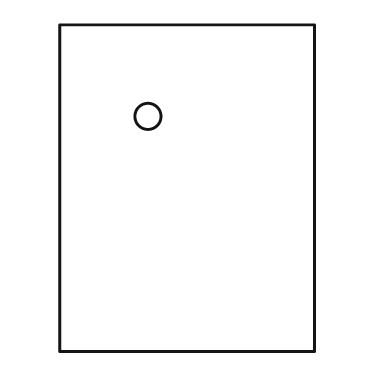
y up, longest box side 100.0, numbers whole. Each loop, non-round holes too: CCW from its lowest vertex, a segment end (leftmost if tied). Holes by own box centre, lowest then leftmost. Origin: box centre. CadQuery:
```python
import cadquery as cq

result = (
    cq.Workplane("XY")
    .moveTo(-39.0, -50.0)
    .lineTo(39.0, -50.0)
    .lineTo(39.0, 50.0)
    .lineTo(-39.0, 50.0)
    .close()
    .moveTo(-12.0, 22.0)
    .circle(4.0)
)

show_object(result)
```